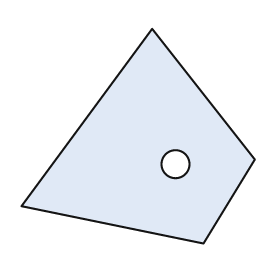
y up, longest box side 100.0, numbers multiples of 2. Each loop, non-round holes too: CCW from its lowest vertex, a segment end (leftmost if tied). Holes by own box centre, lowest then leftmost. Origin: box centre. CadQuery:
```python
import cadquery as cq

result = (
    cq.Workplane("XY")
    .moveTo(28.0, -46.0)
    .lineTo(50.0, -10.0)
    .lineTo(6.0, 46.0)
    .lineTo(-50.0, -30.0)
    .close()
    .moveTo(16.0, -12.0)
    .circle(6.0)
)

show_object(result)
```